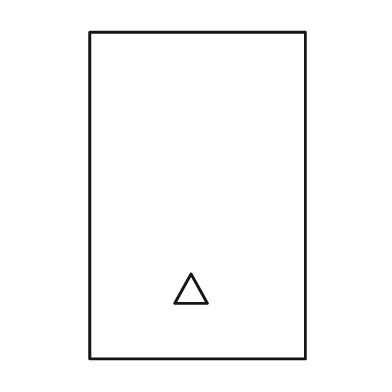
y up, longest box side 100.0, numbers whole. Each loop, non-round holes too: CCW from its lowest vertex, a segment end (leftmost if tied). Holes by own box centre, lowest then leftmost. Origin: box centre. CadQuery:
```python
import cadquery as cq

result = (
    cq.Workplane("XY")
    .moveTo(-33.0, -50.0)
    .lineTo(33.0, -50.0)
    .lineTo(33.0, 50.0)
    .lineTo(-33.0, 50.0)
    .close()
    .moveTo(-7.0, -33.0)
    .lineTo(3.0, -33.0)
    .lineTo(-2.0, -24.0)
    .close()
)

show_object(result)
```